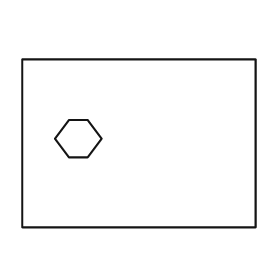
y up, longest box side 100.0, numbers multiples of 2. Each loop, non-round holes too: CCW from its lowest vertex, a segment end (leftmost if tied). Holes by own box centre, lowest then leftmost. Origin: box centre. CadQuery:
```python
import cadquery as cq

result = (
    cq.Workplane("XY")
    .moveTo(-50.0, -36.0)
    .lineTo(50.0, -36.0)
    .lineTo(50.0, 36.0)
    .lineTo(-50.0, 36.0)
    .close()
    .moveTo(-30.0, -6.0)
    .lineTo(-22.0, -6.0)
    .lineTo(-16.0, 2.0)
    .lineTo(-22.0, 10.0)
    .lineTo(-30.0, 10.0)
    .lineTo(-36.0, 2.0)
    .close()
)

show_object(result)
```